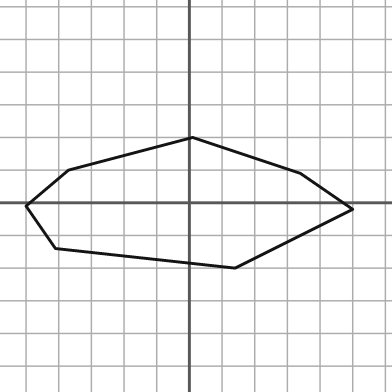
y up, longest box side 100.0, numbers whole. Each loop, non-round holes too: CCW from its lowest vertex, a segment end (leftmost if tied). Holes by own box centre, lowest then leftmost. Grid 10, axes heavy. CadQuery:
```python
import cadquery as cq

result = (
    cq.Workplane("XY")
    .moveTo(14.0, -20.0)
    .lineTo(50.0, -2.0)
    .lineTo(34.0, 9.0)
    .lineTo(1.0, 20.0)
    .lineTo(-37.0, 10.0)
    .lineTo(-50.0, -1.0)
    .lineTo(-41.0, -14.0)
    .close()
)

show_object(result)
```